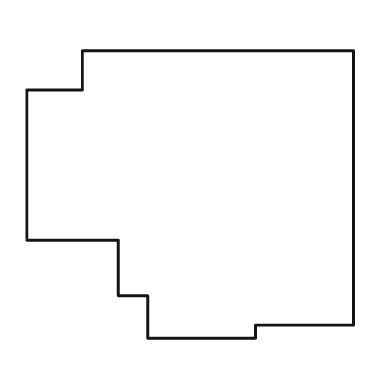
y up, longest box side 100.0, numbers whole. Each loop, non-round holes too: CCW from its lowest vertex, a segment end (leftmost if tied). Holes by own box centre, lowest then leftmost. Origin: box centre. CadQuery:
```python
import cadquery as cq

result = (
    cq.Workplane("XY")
    .moveTo(-13.0, -44.0)
    .lineTo(20.0, -44.0)
    .lineTo(20.0, -40.0)
    .lineTo(50.0, -40.0)
    .lineTo(50.0, 44.0)
    .lineTo(-33.0, 44.0)
    .lineTo(-33.0, 32.0)
    .lineTo(-50.0, 32.0)
    .lineTo(-50.0, -14.0)
    .lineTo(-22.0, -14.0)
    .lineTo(-22.0, -31.0)
    .lineTo(-13.0, -31.0)
    .close()
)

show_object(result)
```